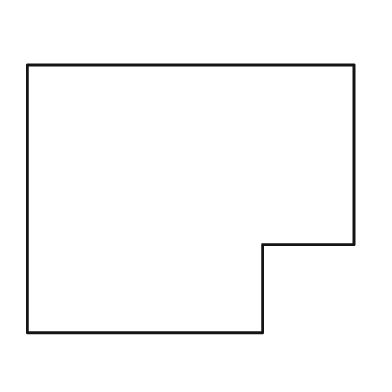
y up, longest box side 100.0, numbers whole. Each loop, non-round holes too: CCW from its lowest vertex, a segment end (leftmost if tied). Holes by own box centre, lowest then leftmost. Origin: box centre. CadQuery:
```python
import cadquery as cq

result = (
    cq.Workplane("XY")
    .moveTo(-50.0, -41.0)
    .lineTo(22.0, -41.0)
    .lineTo(22.0, -14.0)
    .lineTo(50.0, -14.0)
    .lineTo(50.0, 41.0)
    .lineTo(-50.0, 41.0)
    .close()
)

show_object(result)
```